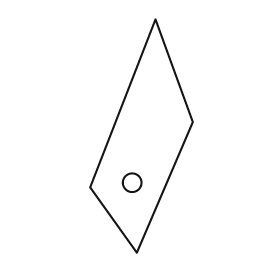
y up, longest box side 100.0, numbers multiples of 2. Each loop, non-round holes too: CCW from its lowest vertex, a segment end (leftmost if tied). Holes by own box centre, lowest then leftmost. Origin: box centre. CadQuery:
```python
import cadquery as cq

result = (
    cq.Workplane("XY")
    .moveTo(-2.0, -50.0)
    .lineTo(22.0, 6.0)
    .lineTo(6.0, 50.0)
    .lineTo(-22.0, -22.0)
    .close()
    .moveTo(-4.0, -20.0)
    .circle(4.0)
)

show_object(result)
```